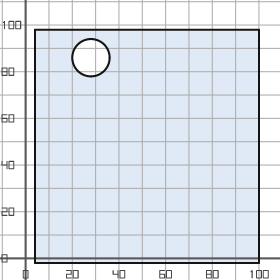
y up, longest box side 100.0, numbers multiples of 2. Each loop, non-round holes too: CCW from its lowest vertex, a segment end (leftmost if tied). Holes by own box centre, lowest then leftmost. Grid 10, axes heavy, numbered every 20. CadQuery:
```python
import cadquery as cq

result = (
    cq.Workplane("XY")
    .moveTo(4.0, -2.0)
    .lineTo(100.0, -2.0)
    .lineTo(100.0, 98.0)
    .lineTo(4.0, 98.0)
    .close()
    .moveTo(28.0, 86.0)
    .circle(8.0)
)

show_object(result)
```